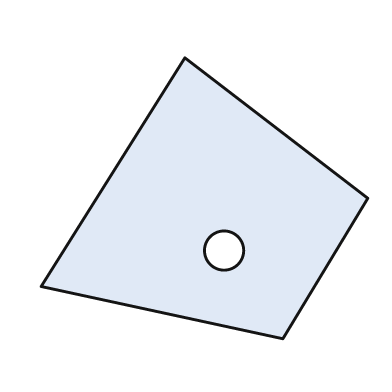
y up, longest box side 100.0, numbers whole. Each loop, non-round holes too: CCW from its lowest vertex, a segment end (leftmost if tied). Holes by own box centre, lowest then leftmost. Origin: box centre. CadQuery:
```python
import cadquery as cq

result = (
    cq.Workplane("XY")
    .moveTo(24.0, -43.0)
    .lineTo(50.0, 0.0)
    .lineTo(-6.0, 43.0)
    .lineTo(-50.0, -27.0)
    .close()
    .moveTo(6.0, -16.0)
    .circle(6.0)
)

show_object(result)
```